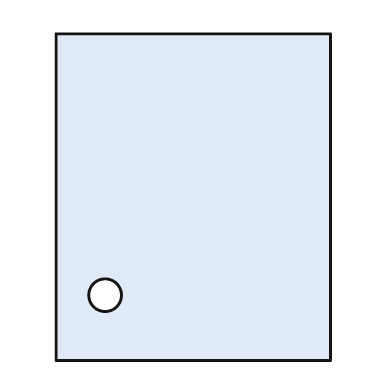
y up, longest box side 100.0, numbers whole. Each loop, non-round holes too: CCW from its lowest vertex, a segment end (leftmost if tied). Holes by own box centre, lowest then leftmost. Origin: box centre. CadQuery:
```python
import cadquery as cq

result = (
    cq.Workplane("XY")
    .moveTo(-42.0, -50.0)
    .lineTo(42.0, -50.0)
    .lineTo(42.0, 50.0)
    .lineTo(-42.0, 50.0)
    .close()
    .moveTo(-27.0, -30.0)
    .circle(5.0)
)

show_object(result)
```